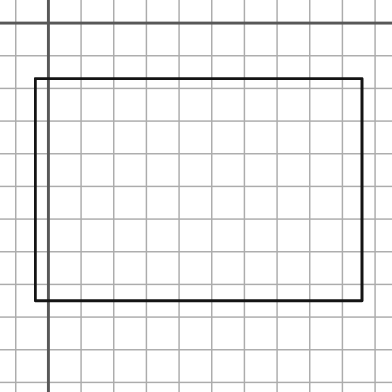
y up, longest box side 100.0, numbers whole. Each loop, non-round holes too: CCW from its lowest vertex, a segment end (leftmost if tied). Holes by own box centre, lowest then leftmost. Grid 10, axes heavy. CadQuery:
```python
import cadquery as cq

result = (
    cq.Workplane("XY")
    .moveTo(-4.0, -85.0)
    .lineTo(96.0, -85.0)
    .lineTo(96.0, -17.0)
    .lineTo(-4.0, -17.0)
    .close()
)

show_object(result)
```